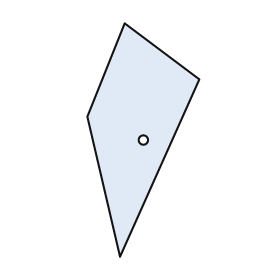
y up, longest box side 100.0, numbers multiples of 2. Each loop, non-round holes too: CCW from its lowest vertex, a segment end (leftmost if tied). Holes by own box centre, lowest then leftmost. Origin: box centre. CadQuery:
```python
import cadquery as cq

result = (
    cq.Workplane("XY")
    .moveTo(-10.0, -50.0)
    .lineTo(24.0, 26.0)
    .lineTo(-8.0, 50.0)
    .lineTo(-24.0, 10.0)
    .close()
    .moveTo(0.0, 0.0)
    .circle(2.0)
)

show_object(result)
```